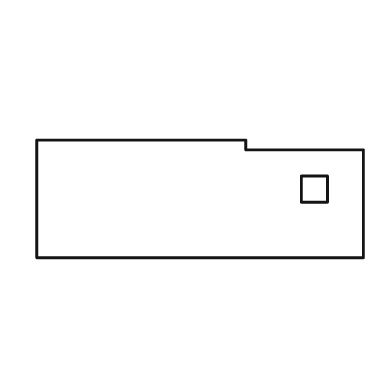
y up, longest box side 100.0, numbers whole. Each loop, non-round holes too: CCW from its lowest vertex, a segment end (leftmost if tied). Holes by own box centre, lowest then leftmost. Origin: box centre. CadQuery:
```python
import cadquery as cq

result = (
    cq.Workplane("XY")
    .moveTo(-50.0, -18.0)
    .lineTo(50.0, -18.0)
    .lineTo(50.0, 15.0)
    .lineTo(14.0, 15.0)
    .lineTo(14.0, 18.0)
    .lineTo(-50.0, 18.0)
    .close()
    .moveTo(31.0, -1.0)
    .lineTo(39.0, -1.0)
    .lineTo(39.0, 7.0)
    .lineTo(31.0, 7.0)
    .close()
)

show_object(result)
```